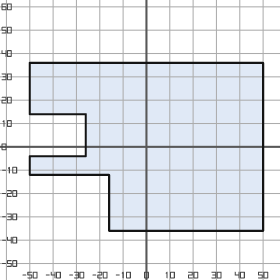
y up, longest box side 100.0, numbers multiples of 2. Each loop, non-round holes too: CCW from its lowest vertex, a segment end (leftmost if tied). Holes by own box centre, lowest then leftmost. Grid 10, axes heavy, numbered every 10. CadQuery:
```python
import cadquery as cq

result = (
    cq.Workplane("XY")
    .moveTo(-16.0, -36.0)
    .lineTo(50.0, -36.0)
    .lineTo(50.0, 36.0)
    .lineTo(-50.0, 36.0)
    .lineTo(-50.0, 14.0)
    .lineTo(-26.0, 14.0)
    .lineTo(-26.0, -4.0)
    .lineTo(-50.0, -4.0)
    .lineTo(-50.0, -12.0)
    .lineTo(-16.0, -12.0)
    .close()
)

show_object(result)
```